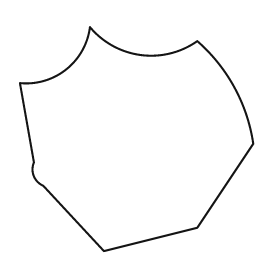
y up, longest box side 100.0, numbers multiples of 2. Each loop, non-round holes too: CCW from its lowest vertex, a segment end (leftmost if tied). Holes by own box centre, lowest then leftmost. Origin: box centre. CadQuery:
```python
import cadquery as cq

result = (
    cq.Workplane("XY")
    .moveTo(-14.0, -48.0)
    .lineTo(26.0, -38.0)
    .lineTo(50.0, -2.0)
    .threePointArc((42.0, 22.0), (26.0, 42.0))
    .threePointArc((2.0, 36.0), (-20.0, 48.0))
    .threePointArc((-30.0, 30.0), (-50.0, 24.0))
    .lineTo(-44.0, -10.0)
    .threePointArc((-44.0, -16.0), (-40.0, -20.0))
    .close()
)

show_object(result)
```